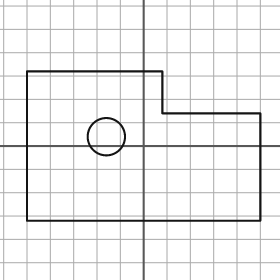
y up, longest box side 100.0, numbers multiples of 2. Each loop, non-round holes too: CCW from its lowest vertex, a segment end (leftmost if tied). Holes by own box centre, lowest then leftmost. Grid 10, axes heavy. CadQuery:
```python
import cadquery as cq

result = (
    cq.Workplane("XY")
    .moveTo(-50.0, -32.0)
    .lineTo(50.0, -32.0)
    .lineTo(50.0, 14.0)
    .lineTo(8.0, 14.0)
    .lineTo(8.0, 32.0)
    .lineTo(-50.0, 32.0)
    .close()
    .moveTo(-16.0, 4.0)
    .circle(8.0)
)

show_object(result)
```